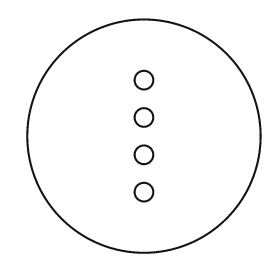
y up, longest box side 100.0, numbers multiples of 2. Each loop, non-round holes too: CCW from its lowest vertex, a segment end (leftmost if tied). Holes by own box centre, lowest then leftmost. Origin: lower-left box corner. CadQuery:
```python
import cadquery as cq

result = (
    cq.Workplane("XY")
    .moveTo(50.0, 50.0)
    .circle(50.0)
    .moveTo(50.0, 26.0)
    .circle(4.0)
    .moveTo(50.0, 42.0)
    .circle(4.0)
    .moveTo(50.0, 58.0)
    .circle(4.0)
    .moveTo(50.0, 74.0)
    .circle(4.0)
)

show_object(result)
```